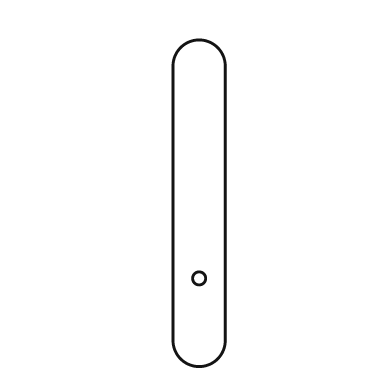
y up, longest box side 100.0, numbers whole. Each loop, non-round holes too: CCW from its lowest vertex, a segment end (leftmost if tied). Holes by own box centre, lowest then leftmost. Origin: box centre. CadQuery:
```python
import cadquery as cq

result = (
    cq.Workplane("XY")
    .moveTo(-8.0, -42.0)
    .threePointArc((0.0, -50.0), (8.0, -42.0))
    .lineTo(8.0, 42.0)
    .threePointArc((0.0, 50.0), (-8.0, 42.0))
    .close()
    .moveTo(0.0, -23.0)
    .circle(2.0)
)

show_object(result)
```